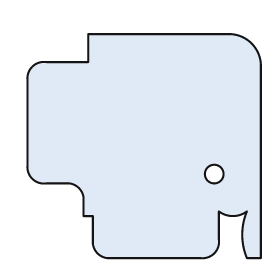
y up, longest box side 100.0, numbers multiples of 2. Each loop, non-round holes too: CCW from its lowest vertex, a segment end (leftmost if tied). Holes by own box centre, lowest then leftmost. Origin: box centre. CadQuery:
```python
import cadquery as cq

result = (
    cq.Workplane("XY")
    .moveTo(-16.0, -48.0)
    .lineTo(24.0, -48.0)
    .threePointArc((30.0, -46.0), (32.0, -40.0))
    .lineTo(32.0, -28.0)
    .threePointArc((38.0, -30.0), (44.0, -28.0))
    .threePointArc((42.0, -38.0), (44.0, -48.0))
    .lineTo(50.0, -48.0)
    .lineTo(50.0, 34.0)
    .threePointArc((46.0, 44.0), (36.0, 48.0))
    .lineTo(-24.0, 48.0)
    .lineTo(-24.0, 36.0)
    .lineTo(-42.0, 36.0)
    .threePointArc((-48.0, 34.0), (-50.0, 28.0))
    .lineTo(-50.0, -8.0)
    .threePointArc((-48.0, -14.0), (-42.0, -16.0))
    .lineTo(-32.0, -16.0)
    .threePointArc((-28.0, -18.0), (-26.0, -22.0))
    .lineTo(-26.0, -30.0)
    .lineTo(-22.0, -30.0)
    .lineTo(-22.0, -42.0)
    .threePointArc((-20.0, -46.0), (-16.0, -48.0))
    .close()
    .moveTo(30.0, -12.0)
    .circle(4.0)
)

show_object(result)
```